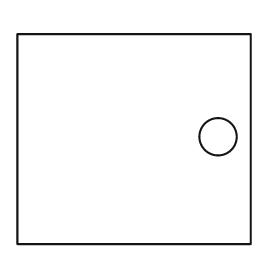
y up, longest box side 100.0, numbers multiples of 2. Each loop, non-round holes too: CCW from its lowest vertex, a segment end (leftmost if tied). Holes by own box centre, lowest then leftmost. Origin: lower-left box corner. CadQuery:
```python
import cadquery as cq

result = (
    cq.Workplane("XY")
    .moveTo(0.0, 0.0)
    .lineTo(100.0, 0.0)
    .lineTo(100.0, 90.0)
    .lineTo(0.0, 90.0)
    .close()
    .moveTo(86.0, 46.0)
    .circle(8.0)
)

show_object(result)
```